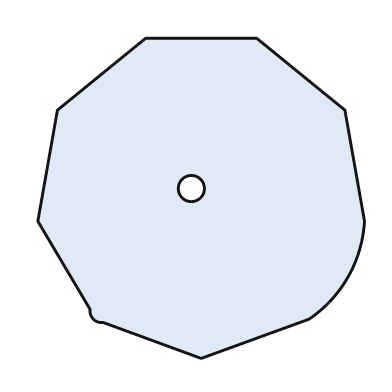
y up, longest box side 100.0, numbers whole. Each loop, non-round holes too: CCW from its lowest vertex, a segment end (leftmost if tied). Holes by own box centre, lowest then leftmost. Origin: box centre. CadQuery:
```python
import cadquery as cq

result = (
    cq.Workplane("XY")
    .moveTo(0.0, -49.0)
    .lineTo(33.0, -37.0)
    .threePointArc((45.0, -24.0), (50.0, -7.0))
    .lineTo(44.0, 27.0)
    .lineTo(17.0, 49.0)
    .lineTo(-17.0, 49.0)
    .lineTo(-44.0, 27.0)
    .lineTo(-50.0, -7.0)
    .lineTo(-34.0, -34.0)
    .threePointArc((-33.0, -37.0), (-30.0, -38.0))
    .close()
    .moveTo(-3.0, 3.0)
    .circle(4.0)
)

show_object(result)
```